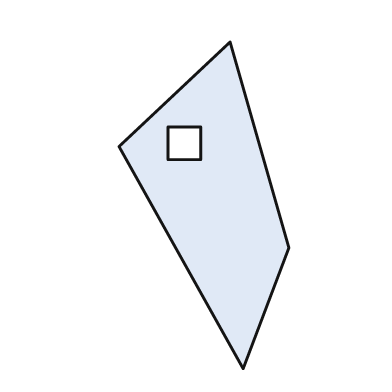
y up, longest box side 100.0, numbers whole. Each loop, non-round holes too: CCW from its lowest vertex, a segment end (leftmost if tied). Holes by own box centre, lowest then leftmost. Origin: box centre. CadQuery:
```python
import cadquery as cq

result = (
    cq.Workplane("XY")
    .moveTo(12.0, -50.0)
    .lineTo(26.0, -13.0)
    .lineTo(8.0, 50.0)
    .lineTo(-26.0, 18.0)
    .close()
    .moveTo(-11.0, 14.0)
    .lineTo(-1.0, 14.0)
    .lineTo(-1.0, 24.0)
    .lineTo(-11.0, 24.0)
    .close()
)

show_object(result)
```